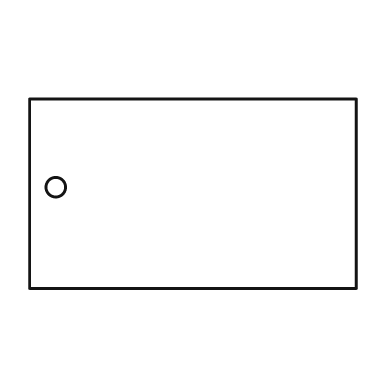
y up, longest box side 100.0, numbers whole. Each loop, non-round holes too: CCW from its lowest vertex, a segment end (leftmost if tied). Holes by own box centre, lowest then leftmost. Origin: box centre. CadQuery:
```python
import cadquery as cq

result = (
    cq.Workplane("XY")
    .moveTo(-50.0, -29.0)
    .lineTo(50.0, -29.0)
    .lineTo(50.0, 29.0)
    .lineTo(-50.0, 29.0)
    .close()
    .moveTo(-42.0, 2.0)
    .circle(3.0)
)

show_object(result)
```